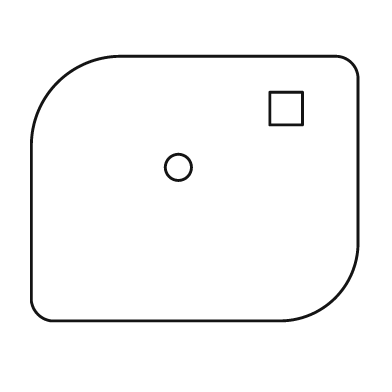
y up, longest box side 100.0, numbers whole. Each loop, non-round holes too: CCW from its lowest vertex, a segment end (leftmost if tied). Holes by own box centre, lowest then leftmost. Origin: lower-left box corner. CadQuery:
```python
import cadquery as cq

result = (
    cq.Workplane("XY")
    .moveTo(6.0, 0.0)
    .lineTo(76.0, 0.0)
    .threePointArc((93.0, 7.0), (100.0, 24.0))
    .lineTo(100.0, 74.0)
    .threePointArc((98.0, 79.0), (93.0, 81.0))
    .lineTo(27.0, 81.0)
    .threePointArc((8.0, 73.0), (0.0, 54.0))
    .lineTo(0.0, 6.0)
    .threePointArc((2.0, 2.0), (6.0, 0.0))
    .close()
    .moveTo(45.0, 47.0)
    .circle(4.0)
    .moveTo(73.0, 60.0)
    .lineTo(83.0, 60.0)
    .lineTo(83.0, 70.0)
    .lineTo(73.0, 70.0)
    .close()
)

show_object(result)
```